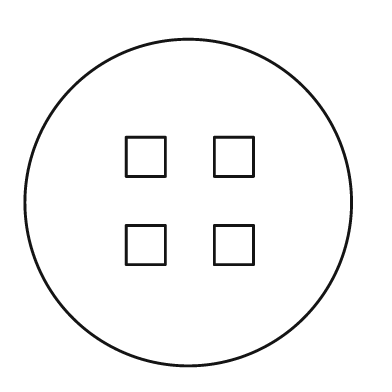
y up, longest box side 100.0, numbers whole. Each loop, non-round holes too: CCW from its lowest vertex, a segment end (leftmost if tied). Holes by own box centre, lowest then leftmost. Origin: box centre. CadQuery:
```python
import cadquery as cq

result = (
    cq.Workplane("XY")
    .moveTo(0.0, 0.0)
    .circle(50.0)
    .moveTo(-19.0, -19.0)
    .lineTo(-7.0, -19.0)
    .lineTo(-7.0, -7.0)
    .lineTo(-19.0, -7.0)
    .close()
    .moveTo(8.0, -19.0)
    .lineTo(20.0, -19.0)
    .lineTo(20.0, -7.0)
    .lineTo(8.0, -7.0)
    .close()
    .moveTo(-19.0, 8.0)
    .lineTo(-7.0, 8.0)
    .lineTo(-7.0, 20.0)
    .lineTo(-19.0, 20.0)
    .close()
    .moveTo(8.0, 8.0)
    .lineTo(20.0, 8.0)
    .lineTo(20.0, 20.0)
    .lineTo(8.0, 20.0)
    .close()
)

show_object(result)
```